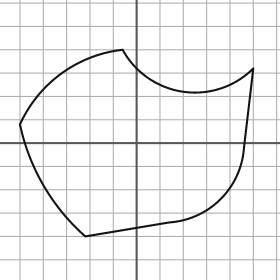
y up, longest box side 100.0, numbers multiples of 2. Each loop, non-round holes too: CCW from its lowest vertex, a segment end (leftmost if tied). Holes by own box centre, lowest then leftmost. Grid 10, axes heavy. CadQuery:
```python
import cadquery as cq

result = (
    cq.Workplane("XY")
    .moveTo(-22.0, -40.0)
    .lineTo(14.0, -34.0)
    .threePointArc((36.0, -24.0), (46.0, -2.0))
    .lineTo(50.0, 32.0)
    .threePointArc((20.0, 22.0), (-6.0, 40.0))
    .threePointArc((-32.0, 30.0), (-50.0, 8.0))
    .threePointArc((-40.0, -18.0), (-22.0, -40.0))
    .close()
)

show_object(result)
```